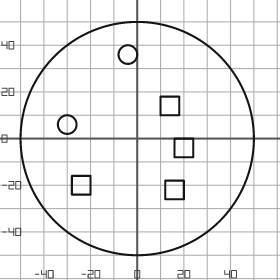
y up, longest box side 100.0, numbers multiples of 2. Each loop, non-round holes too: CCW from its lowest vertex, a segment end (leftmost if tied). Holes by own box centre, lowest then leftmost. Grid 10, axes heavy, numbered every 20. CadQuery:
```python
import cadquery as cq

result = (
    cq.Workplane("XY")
    .moveTo(0.0, 0.0)
    .circle(50.0)
    .moveTo(12.0, -26.0)
    .lineTo(20.0, -26.0)
    .lineTo(20.0, -18.0)
    .lineTo(12.0, -18.0)
    .close()
    .moveTo(-28.0, -24.0)
    .lineTo(-20.0, -24.0)
    .lineTo(-20.0, -16.0)
    .lineTo(-28.0, -16.0)
    .close()
    .moveTo(16.0, -8.0)
    .lineTo(24.0, -8.0)
    .lineTo(24.0, 0.0)
    .lineTo(16.0, 0.0)
    .close()
    .moveTo(-30.0, 6.0)
    .circle(4.0)
    .moveTo(10.0, 10.0)
    .lineTo(18.0, 10.0)
    .lineTo(18.0, 18.0)
    .lineTo(10.0, 18.0)
    .close()
    .moveTo(-4.0, 36.0)
    .circle(4.0)
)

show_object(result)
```